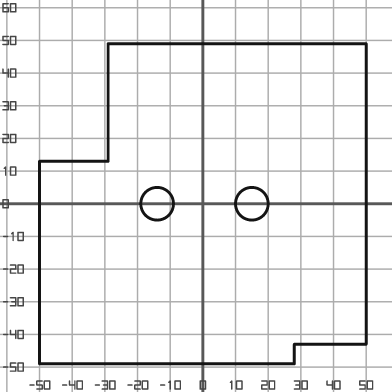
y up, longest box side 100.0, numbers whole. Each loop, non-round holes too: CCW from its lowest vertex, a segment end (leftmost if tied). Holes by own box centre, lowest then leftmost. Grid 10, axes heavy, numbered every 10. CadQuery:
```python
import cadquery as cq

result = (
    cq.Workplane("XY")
    .moveTo(-50.0, -49.0)
    .lineTo(28.0, -49.0)
    .lineTo(28.0, -43.0)
    .lineTo(50.0, -43.0)
    .lineTo(50.0, 49.0)
    .lineTo(-29.0, 49.0)
    .lineTo(-29.0, 13.0)
    .lineTo(-50.0, 13.0)
    .close()
    .moveTo(-14.0, 0.0)
    .circle(5.0)
    .moveTo(15.0, 0.0)
    .circle(5.0)
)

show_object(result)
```